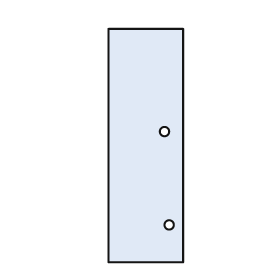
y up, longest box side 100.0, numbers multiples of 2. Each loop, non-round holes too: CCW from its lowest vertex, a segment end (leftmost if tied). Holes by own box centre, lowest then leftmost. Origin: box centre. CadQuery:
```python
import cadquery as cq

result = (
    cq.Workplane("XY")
    .moveTo(-16.0, -50.0)
    .lineTo(16.0, -50.0)
    .lineTo(16.0, 50.0)
    .lineTo(-16.0, 50.0)
    .close()
    .moveTo(10.0, -34.0)
    .circle(2.0)
    .moveTo(8.0, 6.0)
    .circle(2.0)
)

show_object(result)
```